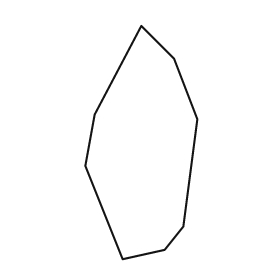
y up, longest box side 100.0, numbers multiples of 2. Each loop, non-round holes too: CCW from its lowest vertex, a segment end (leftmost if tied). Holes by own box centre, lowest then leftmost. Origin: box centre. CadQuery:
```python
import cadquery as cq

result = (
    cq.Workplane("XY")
    .moveTo(-8.0, -50.0)
    .lineTo(10.0, -46.0)
    .lineTo(18.0, -36.0)
    .lineTo(24.0, 10.0)
    .lineTo(14.0, 36.0)
    .lineTo(0.0, 50.0)
    .lineTo(-20.0, 12.0)
    .lineTo(-24.0, -10.0)
    .close()
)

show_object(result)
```